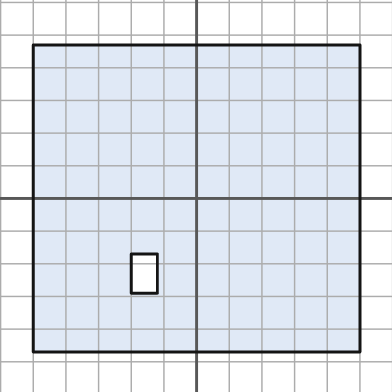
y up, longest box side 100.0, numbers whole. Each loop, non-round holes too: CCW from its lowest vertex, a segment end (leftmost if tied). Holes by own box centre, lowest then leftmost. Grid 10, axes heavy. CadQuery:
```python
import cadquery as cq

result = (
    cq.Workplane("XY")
    .moveTo(-50.0, -47.0)
    .lineTo(50.0, -47.0)
    .lineTo(50.0, 47.0)
    .lineTo(-50.0, 47.0)
    .close()
    .moveTo(-20.0, -29.0)
    .lineTo(-12.0, -29.0)
    .lineTo(-12.0, -17.0)
    .lineTo(-20.0, -17.0)
    .close()
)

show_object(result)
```